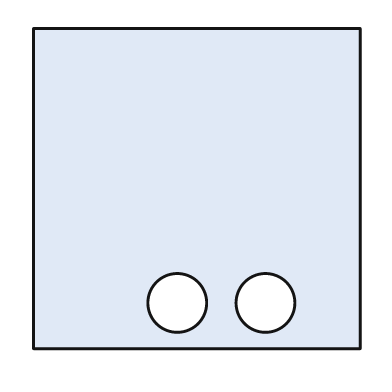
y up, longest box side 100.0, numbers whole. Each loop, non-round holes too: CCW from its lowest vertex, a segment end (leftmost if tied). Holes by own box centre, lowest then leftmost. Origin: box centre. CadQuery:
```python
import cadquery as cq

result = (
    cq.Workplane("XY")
    .moveTo(-50.0, -49.0)
    .lineTo(50.0, -49.0)
    .lineTo(50.0, 49.0)
    .lineTo(-50.0, 49.0)
    .close()
    .moveTo(-6.0, -35.0)
    .circle(9.0)
    .moveTo(21.0, -35.0)
    .circle(9.0)
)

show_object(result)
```